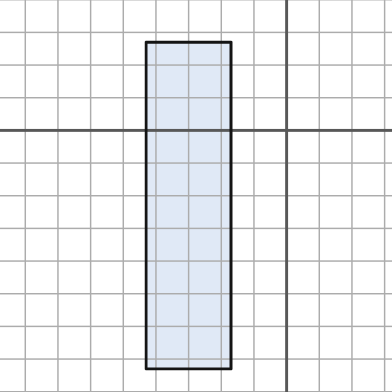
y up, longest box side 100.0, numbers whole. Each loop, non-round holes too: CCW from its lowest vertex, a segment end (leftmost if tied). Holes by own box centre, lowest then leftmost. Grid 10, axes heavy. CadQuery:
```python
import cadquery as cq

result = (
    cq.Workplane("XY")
    .moveTo(-43.0, -73.0)
    .lineTo(-17.0, -73.0)
    .lineTo(-17.0, 27.0)
    .lineTo(-43.0, 27.0)
    .close()
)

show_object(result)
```